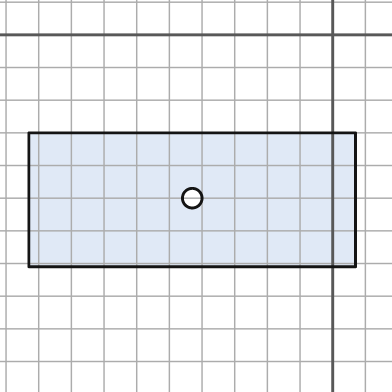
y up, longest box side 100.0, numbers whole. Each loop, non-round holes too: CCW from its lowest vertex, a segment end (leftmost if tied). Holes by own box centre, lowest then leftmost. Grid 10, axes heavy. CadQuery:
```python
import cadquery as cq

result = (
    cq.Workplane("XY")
    .moveTo(-93.0, -71.0)
    .lineTo(7.0, -71.0)
    .lineTo(7.0, -30.0)
    .lineTo(-93.0, -30.0)
    .close()
    .moveTo(-43.0, -50.0)
    .circle(3.0)
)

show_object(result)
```